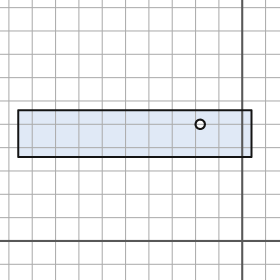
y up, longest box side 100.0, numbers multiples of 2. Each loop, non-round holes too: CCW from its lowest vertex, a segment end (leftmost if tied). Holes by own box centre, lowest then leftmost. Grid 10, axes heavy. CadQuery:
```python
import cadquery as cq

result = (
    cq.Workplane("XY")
    .moveTo(-96.0, 36.0)
    .lineTo(4.0, 36.0)
    .lineTo(4.0, 56.0)
    .lineTo(-96.0, 56.0)
    .close()
    .moveTo(-18.0, 50.0)
    .circle(2.0)
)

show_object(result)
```